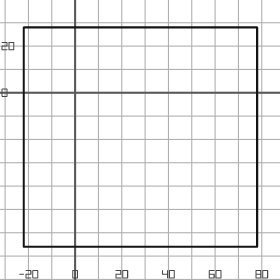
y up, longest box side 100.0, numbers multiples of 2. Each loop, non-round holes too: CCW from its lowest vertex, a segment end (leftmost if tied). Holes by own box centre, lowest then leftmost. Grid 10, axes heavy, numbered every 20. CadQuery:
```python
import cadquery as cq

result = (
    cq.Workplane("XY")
    .moveTo(-22.0, -66.0)
    .lineTo(78.0, -66.0)
    .lineTo(78.0, 28.0)
    .lineTo(-22.0, 28.0)
    .close()
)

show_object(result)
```